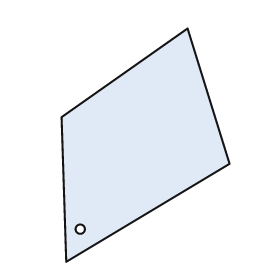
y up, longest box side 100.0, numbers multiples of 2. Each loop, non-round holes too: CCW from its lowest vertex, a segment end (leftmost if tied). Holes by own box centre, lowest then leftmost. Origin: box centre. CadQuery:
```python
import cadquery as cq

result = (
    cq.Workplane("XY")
    .moveTo(-34.0, -50.0)
    .lineTo(36.0, -8.0)
    .lineTo(18.0, 50.0)
    .lineTo(-36.0, 12.0)
    .close()
    .moveTo(-28.0, -36.0)
    .circle(2.0)
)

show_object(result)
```